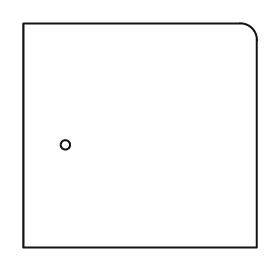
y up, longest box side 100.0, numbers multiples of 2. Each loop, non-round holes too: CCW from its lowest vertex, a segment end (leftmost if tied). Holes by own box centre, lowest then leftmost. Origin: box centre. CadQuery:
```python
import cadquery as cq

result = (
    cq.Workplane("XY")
    .moveTo(-50.0, -48.0)
    .lineTo(50.0, -48.0)
    .lineTo(50.0, 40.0)
    .threePointArc((48.0, 46.0), (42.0, 48.0))
    .lineTo(-50.0, 48.0)
    .close()
    .moveTo(-32.0, -4.0)
    .circle(2.0)
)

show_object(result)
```